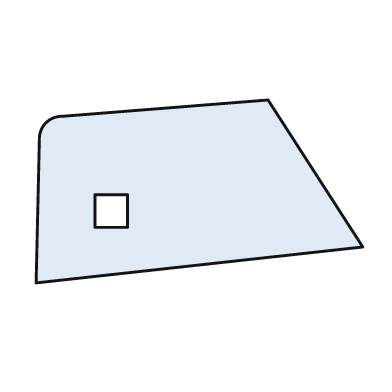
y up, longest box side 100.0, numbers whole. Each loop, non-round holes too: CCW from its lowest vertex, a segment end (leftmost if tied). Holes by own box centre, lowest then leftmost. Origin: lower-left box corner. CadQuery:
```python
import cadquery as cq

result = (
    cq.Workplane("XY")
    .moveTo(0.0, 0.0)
    .lineTo(100.0, 11.0)
    .lineTo(71.0, 56.0)
    .lineTo(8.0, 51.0)
    .threePointArc((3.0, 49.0), (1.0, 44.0))
    .close()
    .moveTo(18.0, 17.0)
    .lineTo(28.0, 17.0)
    .lineTo(28.0, 27.0)
    .lineTo(18.0, 27.0)
    .close()
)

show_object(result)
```